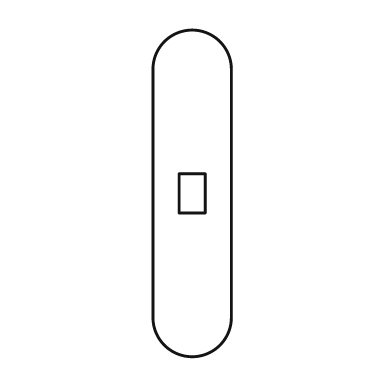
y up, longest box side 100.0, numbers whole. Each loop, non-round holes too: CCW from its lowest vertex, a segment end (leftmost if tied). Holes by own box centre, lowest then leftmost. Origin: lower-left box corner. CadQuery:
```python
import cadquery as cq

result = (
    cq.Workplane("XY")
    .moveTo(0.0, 12.0)
    .threePointArc((12.0, 0.0), (24.0, 12.0))
    .lineTo(24.0, 88.0)
    .threePointArc((12.0, 100.0), (0.0, 88.0))
    .close()
    .moveTo(8.0, 44.0)
    .lineTo(16.0, 44.0)
    .lineTo(16.0, 56.0)
    .lineTo(8.0, 56.0)
    .close()
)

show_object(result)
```